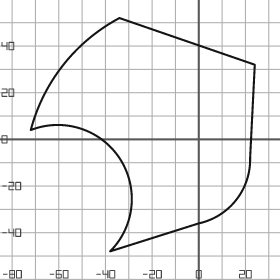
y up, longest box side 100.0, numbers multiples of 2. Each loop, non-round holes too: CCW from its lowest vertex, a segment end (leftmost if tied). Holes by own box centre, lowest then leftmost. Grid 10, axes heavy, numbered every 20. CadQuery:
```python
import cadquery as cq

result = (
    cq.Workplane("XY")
    .moveTo(-38.0, -48.0)
    .lineTo(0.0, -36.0)
    .threePointArc((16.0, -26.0), (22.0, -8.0))
    .lineTo(24.0, 32.0)
    .lineTo(-34.0, 52.0)
    .threePointArc((-58.0, 32.0), (-72.0, 4.0))
    .threePointArc((-34.0, -8.0), (-38.0, -48.0))
    .close()
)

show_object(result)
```